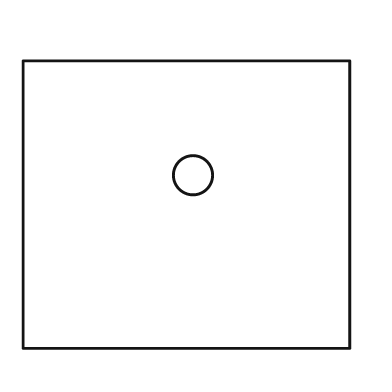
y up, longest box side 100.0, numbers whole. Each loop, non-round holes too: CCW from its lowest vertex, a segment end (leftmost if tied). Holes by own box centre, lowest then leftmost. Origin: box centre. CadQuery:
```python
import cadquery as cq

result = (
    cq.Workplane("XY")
    .moveTo(-50.0, -44.0)
    .lineTo(50.0, -44.0)
    .lineTo(50.0, 44.0)
    .lineTo(-50.0, 44.0)
    .close()
    .moveTo(2.0, 9.0)
    .circle(6.0)
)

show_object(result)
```